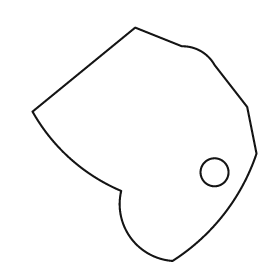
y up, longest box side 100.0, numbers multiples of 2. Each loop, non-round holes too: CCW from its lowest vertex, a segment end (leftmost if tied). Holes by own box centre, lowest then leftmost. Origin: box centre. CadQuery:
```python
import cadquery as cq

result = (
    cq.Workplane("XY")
    .moveTo(12.0, -50.0)
    .threePointArc((34.0, -30.0), (48.0, -4.0))
    .lineTo(44.0, 16.0)
    .lineTo(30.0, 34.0)
    .threePointArc((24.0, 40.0), (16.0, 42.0))
    .lineTo(-4.0, 50.0)
    .lineTo(-48.0, 14.0)
    .threePointArc((-32.0, -6.0), (-10.0, -20.0))
    .threePointArc((-6.0, -40.0), (12.0, -50.0))
    .close()
    .moveTo(30.0, -12.0)
    .circle(6.0)
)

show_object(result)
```